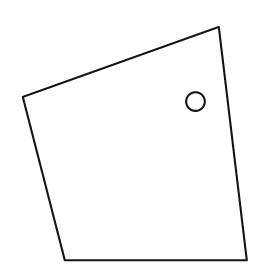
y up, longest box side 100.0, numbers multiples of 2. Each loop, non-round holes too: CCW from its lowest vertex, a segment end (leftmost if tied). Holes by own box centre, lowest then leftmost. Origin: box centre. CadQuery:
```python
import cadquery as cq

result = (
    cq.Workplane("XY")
    .moveTo(-30.0, -50.0)
    .lineTo(48.0, -50.0)
    .lineTo(36.0, 50.0)
    .lineTo(-48.0, 20.0)
    .close()
    .moveTo(26.0, 18.0)
    .circle(4.0)
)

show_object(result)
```